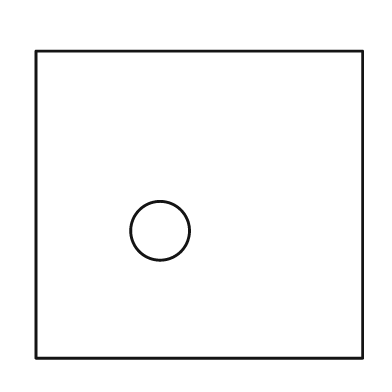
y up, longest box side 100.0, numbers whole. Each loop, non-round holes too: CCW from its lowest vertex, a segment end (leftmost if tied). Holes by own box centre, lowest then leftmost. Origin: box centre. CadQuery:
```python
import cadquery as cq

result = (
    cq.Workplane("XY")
    .moveTo(-50.0, -47.0)
    .lineTo(50.0, -47.0)
    .lineTo(50.0, 47.0)
    .lineTo(-50.0, 47.0)
    .close()
    .moveTo(-12.0, -8.0)
    .circle(9.0)
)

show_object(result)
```